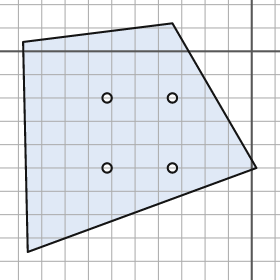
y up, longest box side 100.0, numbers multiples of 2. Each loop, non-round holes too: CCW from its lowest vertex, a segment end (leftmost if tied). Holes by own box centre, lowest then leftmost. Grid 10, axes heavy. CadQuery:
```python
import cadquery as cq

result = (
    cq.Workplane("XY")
    .moveTo(-96.0, -86.0)
    .lineTo(2.0, -50.0)
    .lineTo(-34.0, 12.0)
    .lineTo(-98.0, 4.0)
    .close()
    .moveTo(-62.0, -50.0)
    .circle(2.0)
    .moveTo(-34.0, -50.0)
    .circle(2.0)
    .moveTo(-62.0, -20.0)
    .circle(2.0)
    .moveTo(-34.0, -20.0)
    .circle(2.0)
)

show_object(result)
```